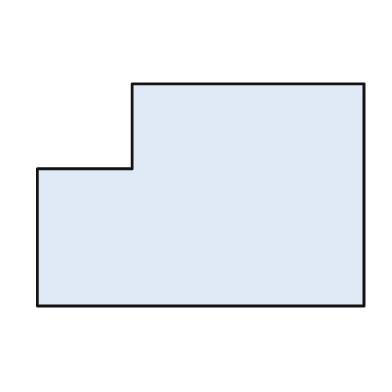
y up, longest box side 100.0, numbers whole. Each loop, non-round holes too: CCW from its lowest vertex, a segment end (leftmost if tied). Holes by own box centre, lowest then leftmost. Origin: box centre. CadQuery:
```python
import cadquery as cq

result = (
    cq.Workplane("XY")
    .moveTo(-50.0, -34.0)
    .lineTo(50.0, -34.0)
    .lineTo(50.0, 34.0)
    .lineTo(-21.0, 34.0)
    .lineTo(-21.0, 8.0)
    .lineTo(-50.0, 8.0)
    .close()
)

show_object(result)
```